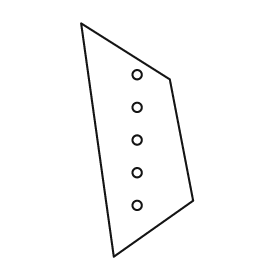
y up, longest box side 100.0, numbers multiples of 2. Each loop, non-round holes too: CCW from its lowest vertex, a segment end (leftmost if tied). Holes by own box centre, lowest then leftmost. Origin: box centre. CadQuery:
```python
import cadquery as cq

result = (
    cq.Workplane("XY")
    .moveTo(-10.0, -50.0)
    .lineTo(24.0, -26.0)
    .lineTo(14.0, 26.0)
    .lineTo(-24.0, 50.0)
    .close()
    .moveTo(0.0, -28.0)
    .circle(2.0)
    .moveTo(0.0, -14.0)
    .circle(2.0)
    .moveTo(0.0, 0.0)
    .circle(2.0)
    .moveTo(0.0, 14.0)
    .circle(2.0)
    .moveTo(0.0, 28.0)
    .circle(2.0)
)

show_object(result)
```